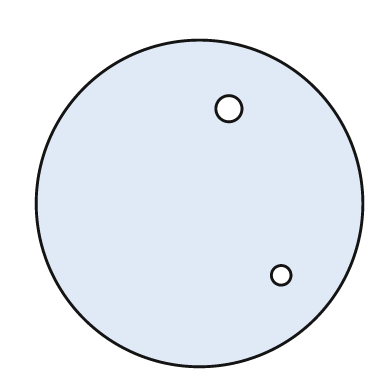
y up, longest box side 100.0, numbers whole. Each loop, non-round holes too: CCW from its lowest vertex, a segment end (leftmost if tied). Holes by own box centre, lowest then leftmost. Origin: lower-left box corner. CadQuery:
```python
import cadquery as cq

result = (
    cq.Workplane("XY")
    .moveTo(50.0, 50.0)
    .circle(50.0)
    .moveTo(75.0, 28.0)
    .circle(3.0)
    .moveTo(59.0, 79.0)
    .circle(4.0)
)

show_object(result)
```